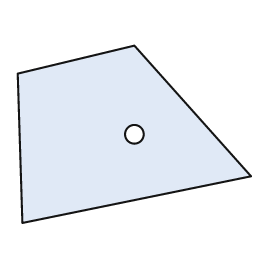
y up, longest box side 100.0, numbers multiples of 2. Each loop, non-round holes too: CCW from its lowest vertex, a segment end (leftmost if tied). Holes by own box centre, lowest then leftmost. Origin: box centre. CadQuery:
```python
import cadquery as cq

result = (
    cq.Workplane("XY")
    .moveTo(-48.0, -38.0)
    .lineTo(50.0, -18.0)
    .lineTo(0.0, 38.0)
    .lineTo(-50.0, 26.0)
    .close()
    .moveTo(0.0, 0.0)
    .circle(4.0)
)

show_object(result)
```